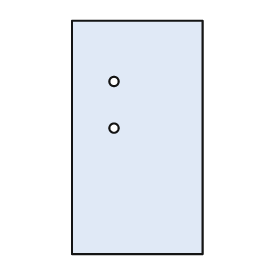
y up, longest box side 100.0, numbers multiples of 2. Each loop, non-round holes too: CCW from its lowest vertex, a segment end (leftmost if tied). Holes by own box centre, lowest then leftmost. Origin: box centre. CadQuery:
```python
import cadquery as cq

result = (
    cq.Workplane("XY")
    .moveTo(-28.0, -50.0)
    .lineTo(28.0, -50.0)
    .lineTo(28.0, 50.0)
    .lineTo(-28.0, 50.0)
    .close()
    .moveTo(-10.0, 4.0)
    .circle(2.0)
    .moveTo(-10.0, 24.0)
    .circle(2.0)
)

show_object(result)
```